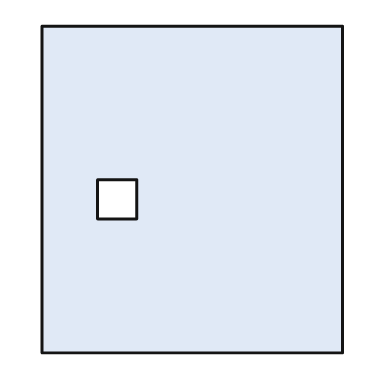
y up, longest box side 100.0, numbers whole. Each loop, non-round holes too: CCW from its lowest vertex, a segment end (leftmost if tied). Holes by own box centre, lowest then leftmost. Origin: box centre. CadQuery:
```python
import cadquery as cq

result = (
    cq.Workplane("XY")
    .moveTo(-46.0, -50.0)
    .lineTo(46.0, -50.0)
    .lineTo(46.0, 50.0)
    .lineTo(-46.0, 50.0)
    .close()
    .moveTo(-29.0, -9.0)
    .lineTo(-17.0, -9.0)
    .lineTo(-17.0, 3.0)
    .lineTo(-29.0, 3.0)
    .close()
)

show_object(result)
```